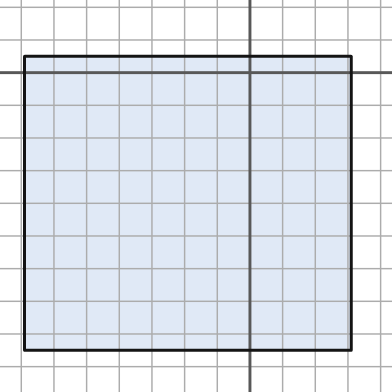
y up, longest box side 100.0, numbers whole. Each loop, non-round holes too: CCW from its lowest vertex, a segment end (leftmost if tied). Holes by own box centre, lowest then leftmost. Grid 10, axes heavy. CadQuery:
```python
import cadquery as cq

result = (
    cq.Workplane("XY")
    .moveTo(-69.0, -85.0)
    .lineTo(31.0, -85.0)
    .lineTo(31.0, 5.0)
    .lineTo(-69.0, 5.0)
    .close()
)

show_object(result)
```